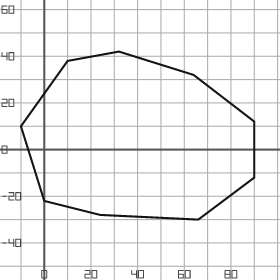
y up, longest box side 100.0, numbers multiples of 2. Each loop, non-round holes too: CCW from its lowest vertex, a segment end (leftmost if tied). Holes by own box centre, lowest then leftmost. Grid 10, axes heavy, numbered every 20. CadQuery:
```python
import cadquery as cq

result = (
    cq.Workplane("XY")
    .moveTo(66.0, -30.0)
    .lineTo(90.0, -12.0)
    .lineTo(90.0, 12.0)
    .lineTo(64.0, 32.0)
    .lineTo(32.0, 42.0)
    .lineTo(10.0, 38.0)
    .lineTo(-10.0, 10.0)
    .lineTo(0.0, -22.0)
    .lineTo(24.0, -28.0)
    .close()
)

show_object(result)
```